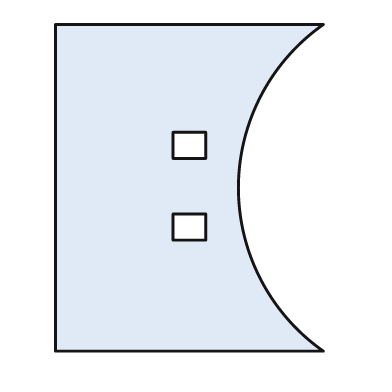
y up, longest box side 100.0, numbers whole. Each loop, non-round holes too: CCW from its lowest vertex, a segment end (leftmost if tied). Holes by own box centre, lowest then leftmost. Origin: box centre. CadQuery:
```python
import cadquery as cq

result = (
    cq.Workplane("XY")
    .moveTo(-41.0, -50.0)
    .lineTo(41.0, -50.0)
    .threePointArc((15.0, 0.0), (41.0, 50.0))
    .lineTo(-41.0, 50.0)
    .close()
    .moveTo(-5.0, -16.0)
    .lineTo(5.0, -16.0)
    .lineTo(5.0, -8.0)
    .lineTo(-5.0, -8.0)
    .close()
    .moveTo(-5.0, 9.0)
    .lineTo(5.0, 9.0)
    .lineTo(5.0, 17.0)
    .lineTo(-5.0, 17.0)
    .close()
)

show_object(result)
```